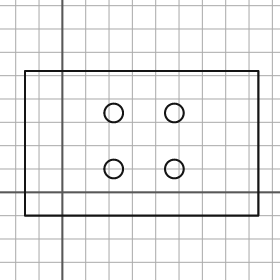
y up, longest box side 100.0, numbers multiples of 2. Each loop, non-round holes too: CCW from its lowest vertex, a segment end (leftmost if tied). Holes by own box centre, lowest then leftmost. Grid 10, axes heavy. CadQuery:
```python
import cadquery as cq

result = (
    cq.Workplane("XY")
    .moveTo(-16.0, -10.0)
    .lineTo(84.0, -10.0)
    .lineTo(84.0, 52.0)
    .lineTo(-16.0, 52.0)
    .close()
    .moveTo(22.0, 10.0)
    .circle(4.0)
    .moveTo(48.0, 10.0)
    .circle(4.0)
    .moveTo(22.0, 34.0)
    .circle(4.0)
    .moveTo(48.0, 34.0)
    .circle(4.0)
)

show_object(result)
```